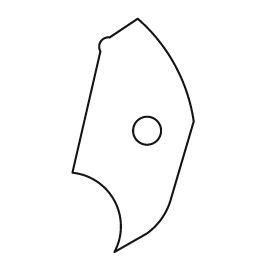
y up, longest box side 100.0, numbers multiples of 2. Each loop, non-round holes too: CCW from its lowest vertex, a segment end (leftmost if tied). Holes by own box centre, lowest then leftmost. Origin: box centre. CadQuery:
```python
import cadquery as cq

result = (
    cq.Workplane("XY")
    .moveTo(-8.0, -50.0)
    .lineTo(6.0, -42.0)
    .threePointArc((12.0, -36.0), (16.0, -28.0))
    .lineTo(26.0, 6.0)
    .threePointArc((18.0, 30.0), (2.0, 50.0))
    .lineTo(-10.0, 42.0)
    .threePointArc((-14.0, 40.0), (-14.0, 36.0))
    .lineTo(-26.0, -16.0)
    .threePointArc((-8.0, -28.0), (-8.0, -50.0))
    .close()
    .moveTo(6.0, 2.0)
    .circle(6.0)
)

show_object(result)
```